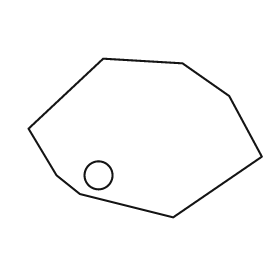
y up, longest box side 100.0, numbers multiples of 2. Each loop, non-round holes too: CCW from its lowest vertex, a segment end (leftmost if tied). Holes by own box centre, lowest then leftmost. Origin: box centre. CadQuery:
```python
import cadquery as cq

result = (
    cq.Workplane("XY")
    .moveTo(12.0, -34.0)
    .lineTo(50.0, -8.0)
    .lineTo(36.0, 18.0)
    .lineTo(16.0, 32.0)
    .lineTo(-18.0, 34.0)
    .lineTo(-50.0, 4.0)
    .lineTo(-38.0, -16.0)
    .lineTo(-28.0, -24.0)
    .close()
    .moveTo(-20.0, -16.0)
    .circle(6.0)
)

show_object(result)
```